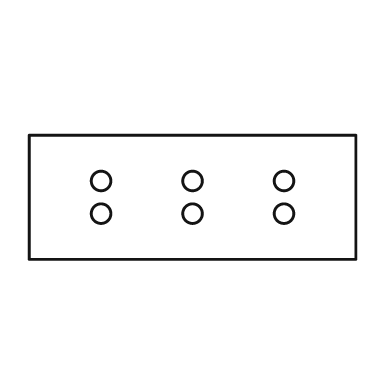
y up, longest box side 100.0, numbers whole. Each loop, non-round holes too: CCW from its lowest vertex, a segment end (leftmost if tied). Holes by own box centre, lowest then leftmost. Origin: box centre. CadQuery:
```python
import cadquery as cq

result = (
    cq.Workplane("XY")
    .moveTo(-50.0, -19.0)
    .lineTo(50.0, -19.0)
    .lineTo(50.0, 19.0)
    .lineTo(-50.0, 19.0)
    .close()
    .moveTo(-28.0, -5.0)
    .circle(3.0)
    .moveTo(0.0, -5.0)
    .circle(3.0)
    .moveTo(28.0, -5.0)
    .circle(3.0)
    .moveTo(-28.0, 5.0)
    .circle(3.0)
    .moveTo(0.0, 5.0)
    .circle(3.0)
    .moveTo(28.0, 5.0)
    .circle(3.0)
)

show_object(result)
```